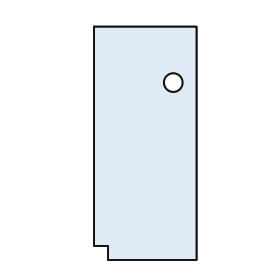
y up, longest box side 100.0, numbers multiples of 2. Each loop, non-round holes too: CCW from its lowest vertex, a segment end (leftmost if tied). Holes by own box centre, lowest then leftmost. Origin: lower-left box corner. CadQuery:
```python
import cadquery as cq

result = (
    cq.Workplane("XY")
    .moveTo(6.0, 0.0)
    .lineTo(44.0, 0.0)
    .lineTo(44.0, 100.0)
    .lineTo(0.0, 100.0)
    .lineTo(0.0, 6.0)
    .lineTo(6.0, 6.0)
    .close()
    .moveTo(34.0, 76.0)
    .circle(4.0)
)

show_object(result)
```